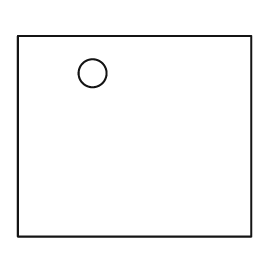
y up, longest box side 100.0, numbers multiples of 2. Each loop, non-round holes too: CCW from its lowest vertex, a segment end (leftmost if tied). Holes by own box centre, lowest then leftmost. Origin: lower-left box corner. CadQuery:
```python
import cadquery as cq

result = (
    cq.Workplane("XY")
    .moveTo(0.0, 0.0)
    .lineTo(100.0, 0.0)
    .lineTo(100.0, 86.0)
    .lineTo(0.0, 86.0)
    .close()
    .moveTo(32.0, 70.0)
    .circle(6.0)
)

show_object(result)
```